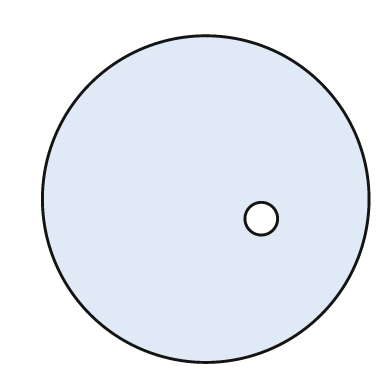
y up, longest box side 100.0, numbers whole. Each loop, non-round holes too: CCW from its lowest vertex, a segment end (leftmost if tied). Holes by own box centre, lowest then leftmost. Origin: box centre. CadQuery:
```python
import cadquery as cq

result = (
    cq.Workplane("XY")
    .moveTo(0.0, 0.0)
    .circle(50.0)
    .moveTo(17.0, -6.0)
    .circle(5.0)
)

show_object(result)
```